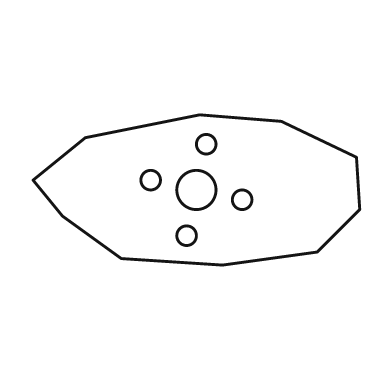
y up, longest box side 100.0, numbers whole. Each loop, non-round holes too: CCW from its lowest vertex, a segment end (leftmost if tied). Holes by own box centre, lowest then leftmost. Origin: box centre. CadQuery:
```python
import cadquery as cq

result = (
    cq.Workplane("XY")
    .moveTo(8.0, -23.0)
    .lineTo(37.0, -19.0)
    .lineTo(50.0, -6.0)
    .lineTo(49.0, 10.0)
    .lineTo(26.0, 21.0)
    .lineTo(1.0, 23.0)
    .lineTo(-34.0, 16.0)
    .lineTo(-50.0, 3.0)
    .lineTo(-41.0, -8.0)
    .lineTo(-23.0, -21.0)
    .close()
    .moveTo(-3.0, -14.0)
    .circle(3.0)
    .moveTo(14.0, -3.0)
    .circle(3.0)
    .moveTo(0.0, 0.0)
    .circle(6.0)
    .moveTo(-14.0, 3.0)
    .circle(3.0)
    .moveTo(3.0, 14.0)
    .circle(3.0)
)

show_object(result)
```